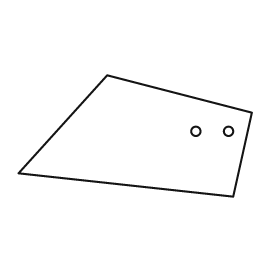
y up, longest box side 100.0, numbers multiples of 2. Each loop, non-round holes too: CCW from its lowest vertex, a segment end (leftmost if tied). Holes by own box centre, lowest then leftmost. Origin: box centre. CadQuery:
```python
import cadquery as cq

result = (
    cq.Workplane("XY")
    .moveTo(42.0, -26.0)
    .lineTo(50.0, 10.0)
    .lineTo(-12.0, 26.0)
    .lineTo(-50.0, -16.0)
    .close()
    .moveTo(26.0, 2.0)
    .circle(2.0)
    .moveTo(40.0, 2.0)
    .circle(2.0)
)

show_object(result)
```